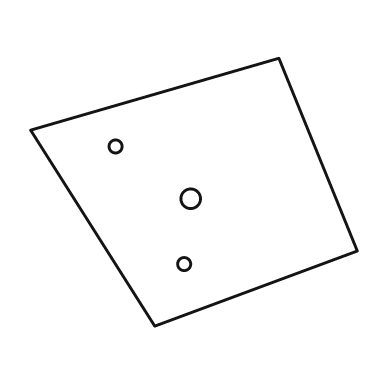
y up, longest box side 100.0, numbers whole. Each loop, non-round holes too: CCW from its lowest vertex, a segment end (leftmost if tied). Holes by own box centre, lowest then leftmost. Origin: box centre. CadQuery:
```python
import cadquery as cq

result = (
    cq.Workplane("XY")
    .moveTo(-12.0, -41.0)
    .lineTo(50.0, -18.0)
    .lineTo(26.0, 41.0)
    .lineTo(-50.0, 19.0)
    .close()
    .moveTo(-3.0, -22.0)
    .circle(2.0)
    .moveTo(-1.0, -2.0)
    .circle(3.0)
    .moveTo(-24.0, 14.0)
    .circle(2.0)
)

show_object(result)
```